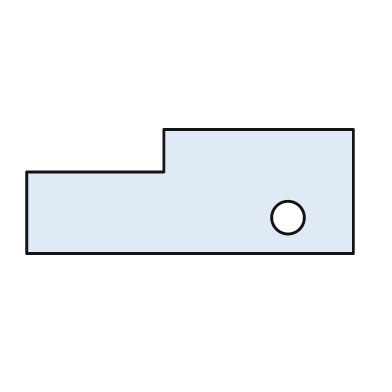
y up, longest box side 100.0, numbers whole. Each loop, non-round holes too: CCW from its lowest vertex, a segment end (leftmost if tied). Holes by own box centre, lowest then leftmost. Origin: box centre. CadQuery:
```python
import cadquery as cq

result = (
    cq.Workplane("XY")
    .moveTo(-50.0, -19.0)
    .lineTo(50.0, -19.0)
    .lineTo(50.0, 19.0)
    .lineTo(-8.0, 19.0)
    .lineTo(-8.0, 6.0)
    .lineTo(-50.0, 6.0)
    .close()
    .moveTo(30.0, -8.0)
    .circle(5.0)
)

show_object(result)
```